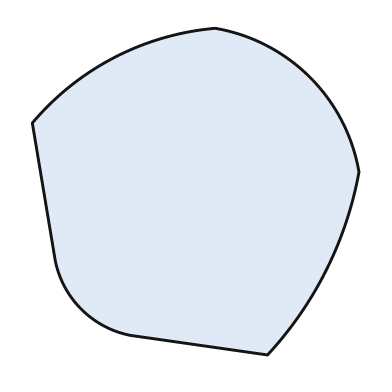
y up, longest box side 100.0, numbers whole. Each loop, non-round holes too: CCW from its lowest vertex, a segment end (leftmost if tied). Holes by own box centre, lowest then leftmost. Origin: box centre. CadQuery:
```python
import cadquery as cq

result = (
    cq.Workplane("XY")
    .moveTo(22.0, -50.0)
    .threePointArc((40.0, -24.0), (50.0, 6.0))
    .threePointArc((35.0, 35.0), (6.0, 50.0))
    .threePointArc((-25.0, 41.0), (-50.0, 21.0))
    .lineTo(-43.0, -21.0)
    .threePointArc((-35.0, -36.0), (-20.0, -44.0))
    .close()
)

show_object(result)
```